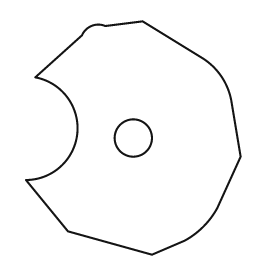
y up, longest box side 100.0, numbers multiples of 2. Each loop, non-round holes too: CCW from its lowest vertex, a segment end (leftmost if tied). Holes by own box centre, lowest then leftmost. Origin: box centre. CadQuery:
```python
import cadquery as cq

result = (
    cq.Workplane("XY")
    .moveTo(8.0, -50.0)
    .lineTo(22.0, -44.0)
    .threePointArc((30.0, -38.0), (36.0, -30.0))
    .lineTo(46.0, -8.0)
    .lineTo(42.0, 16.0)
    .threePointArc((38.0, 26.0), (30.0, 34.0))
    .lineTo(4.0, 50.0)
    .lineTo(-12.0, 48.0)
    .threePointArc((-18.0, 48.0), (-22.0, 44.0))
    .lineTo(-42.0, 26.0)
    .threePointArc((-24.0, 2.0), (-46.0, -18.0))
    .lineTo(-28.0, -40.0)
    .close()
    .moveTo(0.0, 0.0)
    .circle(8.0)
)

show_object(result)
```